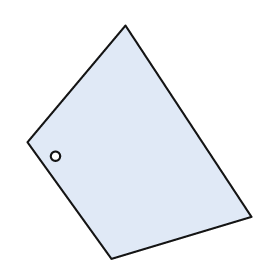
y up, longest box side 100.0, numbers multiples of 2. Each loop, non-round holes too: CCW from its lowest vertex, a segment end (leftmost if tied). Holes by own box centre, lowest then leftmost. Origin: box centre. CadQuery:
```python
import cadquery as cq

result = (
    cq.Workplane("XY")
    .moveTo(-12.0, -50.0)
    .lineTo(48.0, -32.0)
    .lineTo(-6.0, 50.0)
    .lineTo(-48.0, 0.0)
    .close()
    .moveTo(-36.0, -6.0)
    .circle(2.0)
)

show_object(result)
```